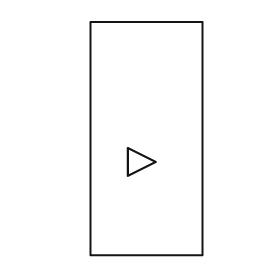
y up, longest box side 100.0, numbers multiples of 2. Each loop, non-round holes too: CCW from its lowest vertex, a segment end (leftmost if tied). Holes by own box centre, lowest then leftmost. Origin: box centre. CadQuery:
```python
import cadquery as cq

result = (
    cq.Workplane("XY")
    .moveTo(-24.0, -50.0)
    .lineTo(24.0, -50.0)
    .lineTo(24.0, 50.0)
    .lineTo(-24.0, 50.0)
    .close()
    .moveTo(-8.0, -16.0)
    .lineTo(4.0, -10.0)
    .lineTo(-8.0, -4.0)
    .close()
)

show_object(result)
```